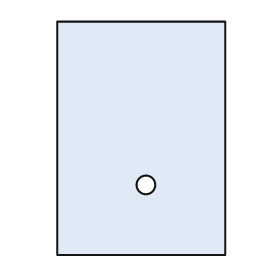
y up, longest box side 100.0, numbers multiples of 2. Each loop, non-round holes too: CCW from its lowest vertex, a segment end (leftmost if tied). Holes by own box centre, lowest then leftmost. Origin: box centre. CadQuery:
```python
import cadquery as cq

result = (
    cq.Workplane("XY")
    .moveTo(-36.0, -50.0)
    .lineTo(36.0, -50.0)
    .lineTo(36.0, 50.0)
    .lineTo(-36.0, 50.0)
    .close()
    .moveTo(2.0, -20.0)
    .circle(4.0)
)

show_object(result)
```